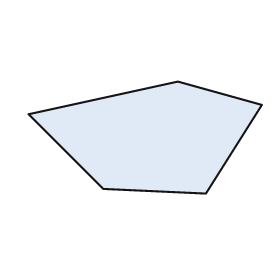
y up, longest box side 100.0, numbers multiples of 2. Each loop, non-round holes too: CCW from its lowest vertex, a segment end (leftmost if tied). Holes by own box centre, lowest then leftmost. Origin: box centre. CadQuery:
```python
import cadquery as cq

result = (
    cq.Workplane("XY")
    .moveTo(26.0, -24.0)
    .lineTo(50.0, 14.0)
    .lineTo(14.0, 24.0)
    .lineTo(-50.0, 10.0)
    .lineTo(-18.0, -22.0)
    .close()
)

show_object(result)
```